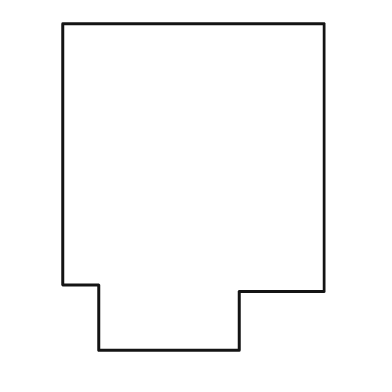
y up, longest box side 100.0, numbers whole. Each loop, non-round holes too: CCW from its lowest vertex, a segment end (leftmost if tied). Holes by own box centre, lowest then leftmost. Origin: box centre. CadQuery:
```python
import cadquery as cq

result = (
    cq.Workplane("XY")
    .moveTo(-29.0, -50.0)
    .lineTo(14.0, -50.0)
    .lineTo(14.0, -32.0)
    .lineTo(40.0, -32.0)
    .lineTo(40.0, 50.0)
    .lineTo(-40.0, 50.0)
    .lineTo(-40.0, -30.0)
    .lineTo(-29.0, -30.0)
    .close()
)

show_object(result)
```